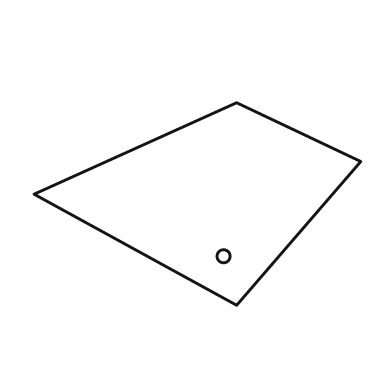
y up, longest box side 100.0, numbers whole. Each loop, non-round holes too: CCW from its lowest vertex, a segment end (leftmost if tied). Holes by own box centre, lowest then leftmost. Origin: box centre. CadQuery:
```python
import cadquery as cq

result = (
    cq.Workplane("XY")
    .moveTo(12.0, -31.0)
    .lineTo(50.0, 13.0)
    .lineTo(12.0, 31.0)
    .lineTo(-50.0, 3.0)
    .close()
    .moveTo(8.0, -16.0)
    .circle(2.0)
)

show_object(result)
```